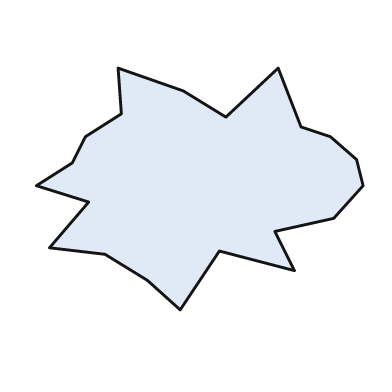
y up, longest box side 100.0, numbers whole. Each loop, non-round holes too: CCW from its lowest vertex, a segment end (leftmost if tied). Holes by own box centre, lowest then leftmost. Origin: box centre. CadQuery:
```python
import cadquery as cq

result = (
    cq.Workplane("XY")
    .moveTo(-6.0, -37.0)
    .lineTo(6.0, -19.0)
    .lineTo(29.0, -25.0)
    .lineTo(23.0, -13.0)
    .lineTo(41.0, -9.0)
    .lineTo(50.0, 1.0)
    .lineTo(48.0, 9.0)
    .lineTo(40.0, 16.0)
    .lineTo(31.0, 19.0)
    .lineTo(24.0, 37.0)
    .lineTo(8.0, 22.0)
    .lineTo(-5.0, 30.0)
    .lineTo(-25.0, 37.0)
    .lineTo(-24.0, 23.0)
    .lineTo(-35.0, 16.0)
    .lineTo(-39.0, 8.0)
    .lineTo(-50.0, 1.0)
    .lineTo(-34.0, -4.0)
    .lineTo(-46.0, -18.0)
    .lineTo(-29.0, -20.0)
    .lineTo(-16.0, -28.0)
    .close()
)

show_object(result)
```